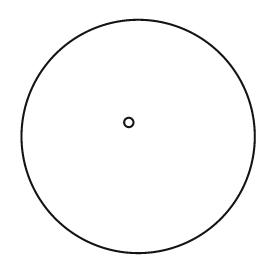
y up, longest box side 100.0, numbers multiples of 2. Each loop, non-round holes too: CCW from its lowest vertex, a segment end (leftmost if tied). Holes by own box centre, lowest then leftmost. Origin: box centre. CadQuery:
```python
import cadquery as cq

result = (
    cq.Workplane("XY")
    .moveTo(0.0, 0.0)
    .circle(50.0)
    .moveTo(-4.0, 6.0)
    .circle(2.0)
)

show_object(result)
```